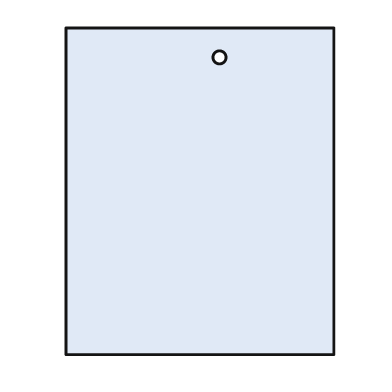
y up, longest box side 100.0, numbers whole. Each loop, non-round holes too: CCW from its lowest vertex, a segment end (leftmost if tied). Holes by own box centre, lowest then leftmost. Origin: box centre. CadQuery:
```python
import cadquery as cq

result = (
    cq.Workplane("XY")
    .moveTo(-41.0, -50.0)
    .lineTo(41.0, -50.0)
    .lineTo(41.0, 50.0)
    .lineTo(-41.0, 50.0)
    .close()
    .moveTo(6.0, 41.0)
    .circle(2.0)
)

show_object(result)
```